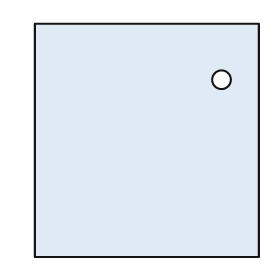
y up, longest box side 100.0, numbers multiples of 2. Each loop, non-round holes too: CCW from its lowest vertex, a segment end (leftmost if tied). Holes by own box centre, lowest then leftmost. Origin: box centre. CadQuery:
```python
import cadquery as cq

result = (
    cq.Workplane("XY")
    .moveTo(-48.0, -50.0)
    .lineTo(48.0, -50.0)
    .lineTo(48.0, 50.0)
    .lineTo(-48.0, 50.0)
    .close()
    .moveTo(32.0, 26.0)
    .circle(4.0)
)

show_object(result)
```